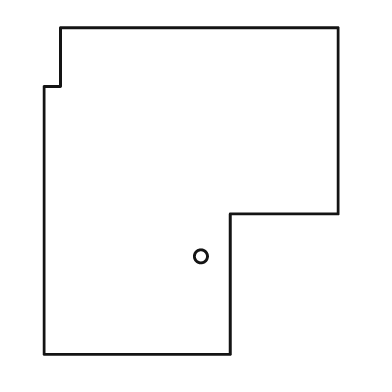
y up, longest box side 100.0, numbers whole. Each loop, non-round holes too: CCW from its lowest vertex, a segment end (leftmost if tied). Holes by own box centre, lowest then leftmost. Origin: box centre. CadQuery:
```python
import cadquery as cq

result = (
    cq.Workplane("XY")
    .moveTo(-45.0, -50.0)
    .lineTo(12.0, -50.0)
    .lineTo(12.0, -7.0)
    .lineTo(45.0, -7.0)
    .lineTo(45.0, 50.0)
    .lineTo(-40.0, 50.0)
    .lineTo(-40.0, 32.0)
    .lineTo(-45.0, 32.0)
    .close()
    .moveTo(3.0, -20.0)
    .circle(2.0)
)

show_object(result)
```